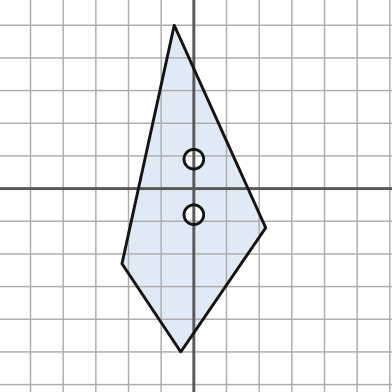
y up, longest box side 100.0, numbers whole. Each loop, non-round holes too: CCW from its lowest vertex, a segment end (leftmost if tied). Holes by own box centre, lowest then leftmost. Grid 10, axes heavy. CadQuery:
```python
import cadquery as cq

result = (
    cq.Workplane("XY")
    .moveTo(-4.0, -50.0)
    .lineTo(22.0, -12.0)
    .lineTo(-6.0, 50.0)
    .lineTo(-22.0, -23.0)
    .close()
    .moveTo(0.0, -8.0)
    .circle(3.0)
    .moveTo(0.0, 9.0)
    .circle(3.0)
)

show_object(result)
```